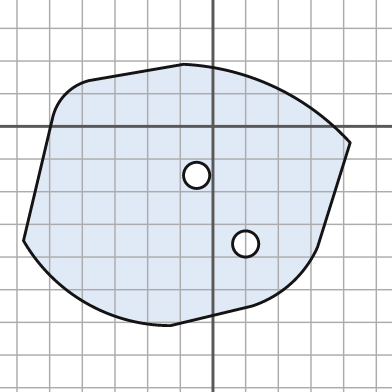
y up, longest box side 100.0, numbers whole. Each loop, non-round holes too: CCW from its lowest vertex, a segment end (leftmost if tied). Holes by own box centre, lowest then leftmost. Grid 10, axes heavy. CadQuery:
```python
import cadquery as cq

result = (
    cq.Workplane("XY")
    .moveTo(-13.0, -61.0)
    .lineTo(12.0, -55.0)
    .threePointArc((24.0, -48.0), (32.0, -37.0))
    .lineTo(42.0, -5.0)
    .threePointArc((19.0, 12.0), (-9.0, 19.0))
    .lineTo(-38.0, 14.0)
    .threePointArc((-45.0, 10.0), (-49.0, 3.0))
    .lineTo(-58.0, -35.0)
    .threePointArc((-39.0, -54.0), (-13.0, -61.0))
    .close()
    .moveTo(10.0, -36.0)
    .circle(4.0)
    .moveTo(-5.0, -15.0)
    .circle(4.0)
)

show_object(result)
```